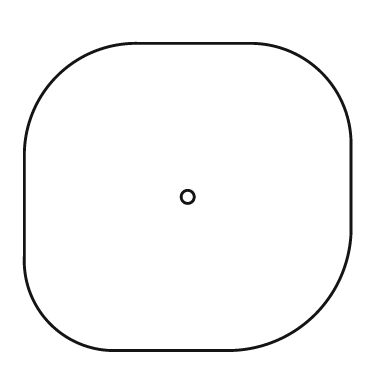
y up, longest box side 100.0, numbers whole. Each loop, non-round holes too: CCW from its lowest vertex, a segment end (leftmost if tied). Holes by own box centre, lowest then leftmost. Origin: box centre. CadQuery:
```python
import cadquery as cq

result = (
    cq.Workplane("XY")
    .moveTo(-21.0, -47.0)
    .lineTo(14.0, -47.0)
    .threePointArc((39.0, -36.0), (50.0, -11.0))
    .lineTo(50.0, 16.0)
    .threePointArc((41.0, 38.0), (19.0, 47.0))
    .lineTo(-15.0, 47.0)
    .threePointArc((-40.0, 37.0), (-50.0, 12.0))
    .lineTo(-50.0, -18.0)
    .threePointArc((-42.0, -39.0), (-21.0, -47.0))
    .close()
    .moveTo(0.0, 0.0)
    .circle(2.0)
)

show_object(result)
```